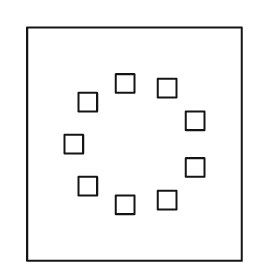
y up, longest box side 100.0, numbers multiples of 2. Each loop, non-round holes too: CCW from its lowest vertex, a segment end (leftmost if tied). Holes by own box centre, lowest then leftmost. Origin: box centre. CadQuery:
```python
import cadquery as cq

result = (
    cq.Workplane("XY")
    .moveTo(-46.0, -50.0)
    .lineTo(46.0, -50.0)
    .lineTo(46.0, 50.0)
    .lineTo(-46.0, 50.0)
    .close()
    .moveTo(-8.0, -30.0)
    .lineTo(0.0, -30.0)
    .lineTo(0.0, -22.0)
    .lineTo(-8.0, -22.0)
    .close()
    .moveTo(10.0, -28.0)
    .lineTo(18.0, -28.0)
    .lineTo(18.0, -20.0)
    .lineTo(10.0, -20.0)
    .close()
    .moveTo(-24.0, -22.0)
    .lineTo(-16.0, -22.0)
    .lineTo(-16.0, -14.0)
    .lineTo(-24.0, -14.0)
    .close()
    .moveTo(22.0, -14.0)
    .lineTo(30.0, -14.0)
    .lineTo(30.0, -6.0)
    .lineTo(22.0, -6.0)
    .close()
    .moveTo(-30.0, -4.0)
    .lineTo(-22.0, -4.0)
    .lineTo(-22.0, 4.0)
    .lineTo(-30.0, 4.0)
    .close()
    .moveTo(22.0, 6.0)
    .lineTo(30.0, 6.0)
    .lineTo(30.0, 14.0)
    .lineTo(22.0, 14.0)
    .close()
    .moveTo(-24.0, 14.0)
    .lineTo(-16.0, 14.0)
    .lineTo(-16.0, 22.0)
    .lineTo(-24.0, 22.0)
    .close()
    .moveTo(10.0, 20.0)
    .lineTo(18.0, 20.0)
    .lineTo(18.0, 28.0)
    .lineTo(10.0, 28.0)
    .close()
    .moveTo(-8.0, 22.0)
    .lineTo(0.0, 22.0)
    .lineTo(0.0, 30.0)
    .lineTo(-8.0, 30.0)
    .close()
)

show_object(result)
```